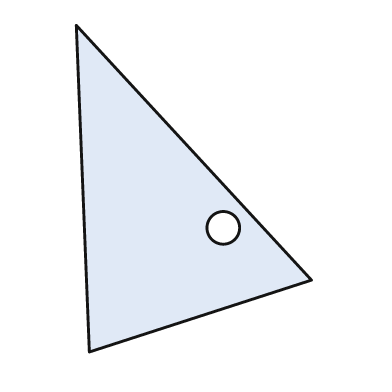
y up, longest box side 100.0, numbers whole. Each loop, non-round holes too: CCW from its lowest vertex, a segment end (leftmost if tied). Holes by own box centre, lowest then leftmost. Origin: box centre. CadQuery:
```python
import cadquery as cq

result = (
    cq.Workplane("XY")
    .moveTo(-32.0, -50.0)
    .lineTo(36.0, -28.0)
    .lineTo(-36.0, 50.0)
    .close()
    .moveTo(9.0, -12.0)
    .circle(5.0)
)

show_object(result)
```